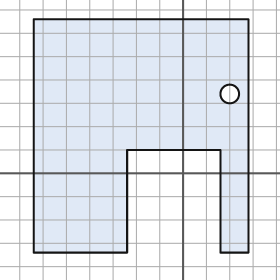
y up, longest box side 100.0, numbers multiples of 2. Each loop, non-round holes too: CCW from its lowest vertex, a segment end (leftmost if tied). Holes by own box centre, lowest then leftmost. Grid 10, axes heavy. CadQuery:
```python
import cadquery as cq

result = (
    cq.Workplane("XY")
    .moveTo(-64.0, -34.0)
    .lineTo(-24.0, -34.0)
    .lineTo(-24.0, 10.0)
    .lineTo(16.0, 10.0)
    .lineTo(16.0, -34.0)
    .lineTo(28.0, -34.0)
    .lineTo(28.0, 66.0)
    .lineTo(-64.0, 66.0)
    .close()
    .moveTo(20.0, 34.0)
    .circle(4.0)
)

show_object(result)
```